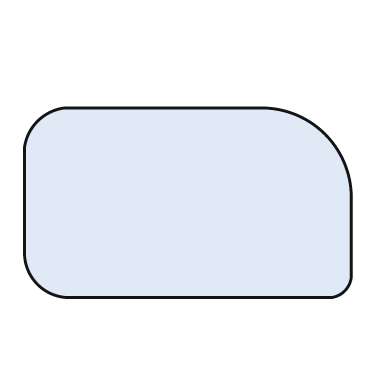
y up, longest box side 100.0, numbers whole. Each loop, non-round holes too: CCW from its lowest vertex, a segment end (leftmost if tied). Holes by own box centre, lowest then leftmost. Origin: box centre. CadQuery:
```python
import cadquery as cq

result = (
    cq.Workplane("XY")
    .moveTo(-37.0, -29.0)
    .lineTo(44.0, -29.0)
    .threePointArc((48.0, -27.0), (50.0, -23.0))
    .lineTo(50.0, 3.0)
    .threePointArc((42.0, 21.0), (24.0, 29.0))
    .lineTo(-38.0, 29.0)
    .threePointArc((-46.0, 25.0), (-50.0, 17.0))
    .lineTo(-50.0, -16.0)
    .threePointArc((-46.0, -25.0), (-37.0, -29.0))
    .close()
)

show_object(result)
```